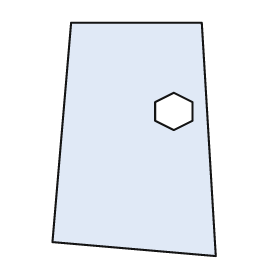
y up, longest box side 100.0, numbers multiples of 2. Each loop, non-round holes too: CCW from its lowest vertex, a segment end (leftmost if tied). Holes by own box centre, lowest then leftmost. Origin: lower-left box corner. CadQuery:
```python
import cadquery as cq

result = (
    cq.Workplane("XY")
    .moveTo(70.0, 0.0)
    .lineTo(64.0, 100.0)
    .lineTo(8.0, 100.0)
    .lineTo(0.0, 6.0)
    .close()
    .moveTo(52.0, 54.0)
    .lineTo(60.0, 58.0)
    .lineTo(60.0, 66.0)
    .lineTo(52.0, 70.0)
    .lineTo(44.0, 66.0)
    .lineTo(44.0, 58.0)
    .close()
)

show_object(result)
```